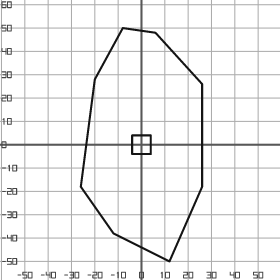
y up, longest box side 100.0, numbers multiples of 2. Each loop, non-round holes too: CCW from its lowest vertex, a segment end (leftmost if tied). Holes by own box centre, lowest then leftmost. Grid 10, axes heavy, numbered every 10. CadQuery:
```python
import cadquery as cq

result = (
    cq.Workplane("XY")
    .moveTo(12.0, -50.0)
    .lineTo(26.0, -18.0)
    .lineTo(26.0, 26.0)
    .lineTo(6.0, 48.0)
    .lineTo(-8.0, 50.0)
    .lineTo(-20.0, 28.0)
    .lineTo(-26.0, -18.0)
    .lineTo(-12.0, -38.0)
    .close()
    .moveTo(-4.0, -4.0)
    .lineTo(4.0, -4.0)
    .lineTo(4.0, 4.0)
    .lineTo(-4.0, 4.0)
    .close()
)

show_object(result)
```